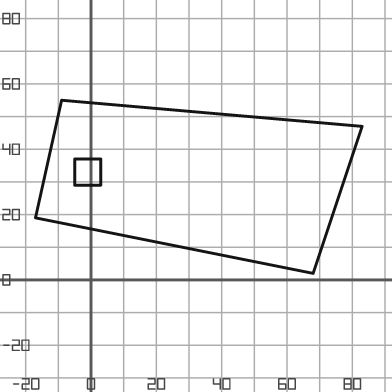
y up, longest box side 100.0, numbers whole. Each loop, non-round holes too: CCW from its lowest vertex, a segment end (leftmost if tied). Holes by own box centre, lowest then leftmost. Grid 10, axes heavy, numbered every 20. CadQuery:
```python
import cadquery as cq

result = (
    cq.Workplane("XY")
    .moveTo(68.0, 2.0)
    .lineTo(83.0, 47.0)
    .lineTo(-9.0, 55.0)
    .lineTo(-17.0, 19.0)
    .close()
    .moveTo(-5.0, 29.0)
    .lineTo(3.0, 29.0)
    .lineTo(3.0, 37.0)
    .lineTo(-5.0, 37.0)
    .close()
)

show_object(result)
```